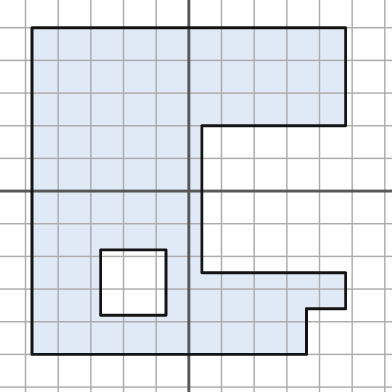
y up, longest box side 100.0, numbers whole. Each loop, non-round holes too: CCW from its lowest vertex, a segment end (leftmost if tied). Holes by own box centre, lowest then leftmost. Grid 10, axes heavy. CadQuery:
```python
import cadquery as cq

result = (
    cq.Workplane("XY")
    .moveTo(-48.0, -50.0)
    .lineTo(36.0, -50.0)
    .lineTo(36.0, -36.0)
    .lineTo(48.0, -36.0)
    .lineTo(48.0, -25.0)
    .lineTo(4.0, -25.0)
    .lineTo(4.0, 20.0)
    .lineTo(48.0, 20.0)
    .lineTo(48.0, 50.0)
    .lineTo(-48.0, 50.0)
    .close()
    .moveTo(-27.0, -38.0)
    .lineTo(-7.0, -38.0)
    .lineTo(-7.0, -18.0)
    .lineTo(-27.0, -18.0)
    .close()
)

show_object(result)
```